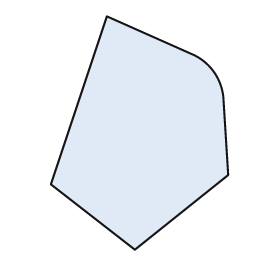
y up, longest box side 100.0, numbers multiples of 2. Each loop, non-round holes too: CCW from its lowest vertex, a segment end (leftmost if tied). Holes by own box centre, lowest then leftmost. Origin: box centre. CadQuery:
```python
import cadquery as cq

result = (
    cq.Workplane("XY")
    .moveTo(-2.0, -50.0)
    .lineTo(38.0, -18.0)
    .lineTo(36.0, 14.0)
    .threePointArc((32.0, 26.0), (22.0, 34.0))
    .lineTo(-14.0, 50.0)
    .lineTo(-38.0, -22.0)
    .close()
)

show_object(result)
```